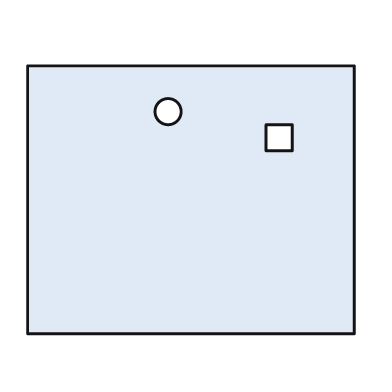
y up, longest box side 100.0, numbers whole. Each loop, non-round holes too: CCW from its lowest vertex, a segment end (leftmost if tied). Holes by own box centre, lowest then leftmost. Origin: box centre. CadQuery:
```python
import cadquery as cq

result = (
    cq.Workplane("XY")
    .moveTo(-50.0, -41.0)
    .lineTo(50.0, -41.0)
    .lineTo(50.0, 41.0)
    .lineTo(-50.0, 41.0)
    .close()
    .moveTo(23.0, 15.0)
    .lineTo(31.0, 15.0)
    .lineTo(31.0, 23.0)
    .lineTo(23.0, 23.0)
    .close()
    .moveTo(-7.0, 27.0)
    .circle(4.0)
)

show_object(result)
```